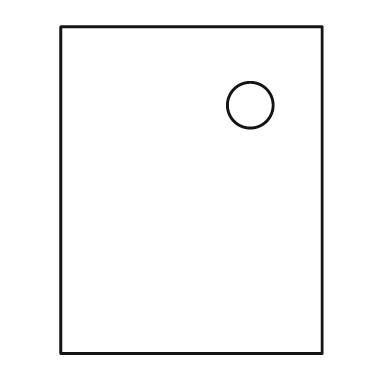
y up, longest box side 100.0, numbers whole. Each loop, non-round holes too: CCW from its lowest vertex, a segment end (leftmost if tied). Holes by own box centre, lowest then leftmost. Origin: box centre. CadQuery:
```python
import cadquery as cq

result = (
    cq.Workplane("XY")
    .moveTo(-40.0, -50.0)
    .lineTo(40.0, -50.0)
    .lineTo(40.0, 50.0)
    .lineTo(-40.0, 50.0)
    .close()
    .moveTo(18.0, 26.0)
    .circle(7.0)
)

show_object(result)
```